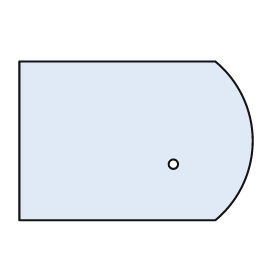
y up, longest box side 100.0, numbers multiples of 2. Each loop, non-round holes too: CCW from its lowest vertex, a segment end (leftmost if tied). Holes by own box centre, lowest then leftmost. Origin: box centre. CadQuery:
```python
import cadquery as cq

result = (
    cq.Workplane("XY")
    .moveTo(-50.0, -34.0)
    .lineTo(34.0, -34.0)
    .threePointArc((50.0, 0.0), (34.0, 34.0))
    .lineTo(-50.0, 34.0)
    .close()
    .moveTo(16.0, -10.0)
    .circle(2.0)
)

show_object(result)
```